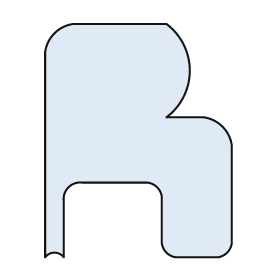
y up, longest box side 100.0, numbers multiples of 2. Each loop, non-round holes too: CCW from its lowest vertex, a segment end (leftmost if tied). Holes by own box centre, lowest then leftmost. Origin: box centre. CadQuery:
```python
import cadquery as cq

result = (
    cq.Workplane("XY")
    .moveTo(-40.0, -50.0)
    .threePointArc((-36.0, -48.0), (-32.0, -50.0))
    .lineTo(-32.0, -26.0)
    .threePointArc((-30.0, -20.0), (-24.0, -18.0))
    .lineTo(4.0, -18.0)
    .threePointArc((8.0, -20.0), (10.0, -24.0))
    .lineTo(10.0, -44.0)
    .threePointArc((12.0, -48.0), (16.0, -50.0))
    .lineTo(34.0, -50.0)
    .threePointArc((38.0, -48.0), (40.0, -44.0))
    .lineTo(40.0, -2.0)
    .threePointArc((36.0, 6.0), (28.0, 10.0))
    .lineTo(12.0, 10.0)
    .threePointArc((22.0, 30.0), (12.0, 50.0))
    .lineTo(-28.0, 50.0)
    .threePointArc((-36.0, 46.0), (-40.0, 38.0))
    .close()
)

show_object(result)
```